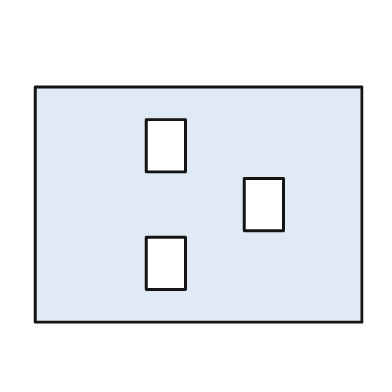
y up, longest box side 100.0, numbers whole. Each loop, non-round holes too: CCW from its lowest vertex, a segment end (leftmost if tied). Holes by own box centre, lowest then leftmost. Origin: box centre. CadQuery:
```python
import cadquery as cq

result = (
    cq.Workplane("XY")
    .moveTo(-50.0, -36.0)
    .lineTo(50.0, -36.0)
    .lineTo(50.0, 36.0)
    .lineTo(-50.0, 36.0)
    .close()
    .moveTo(-16.0, -26.0)
    .lineTo(-4.0, -26.0)
    .lineTo(-4.0, -10.0)
    .lineTo(-16.0, -10.0)
    .close()
    .moveTo(14.0, -8.0)
    .lineTo(26.0, -8.0)
    .lineTo(26.0, 8.0)
    .lineTo(14.0, 8.0)
    .close()
    .moveTo(-16.0, 10.0)
    .lineTo(-4.0, 10.0)
    .lineTo(-4.0, 26.0)
    .lineTo(-16.0, 26.0)
    .close()
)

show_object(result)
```